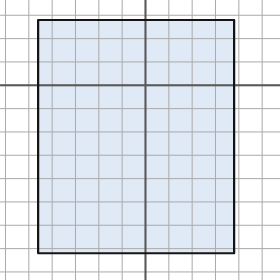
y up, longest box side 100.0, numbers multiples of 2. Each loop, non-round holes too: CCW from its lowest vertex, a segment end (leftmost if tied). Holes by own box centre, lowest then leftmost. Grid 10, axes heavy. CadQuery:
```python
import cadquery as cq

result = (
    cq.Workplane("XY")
    .moveTo(-46.0, -72.0)
    .lineTo(38.0, -72.0)
    .lineTo(38.0, 28.0)
    .lineTo(-46.0, 28.0)
    .close()
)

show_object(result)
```